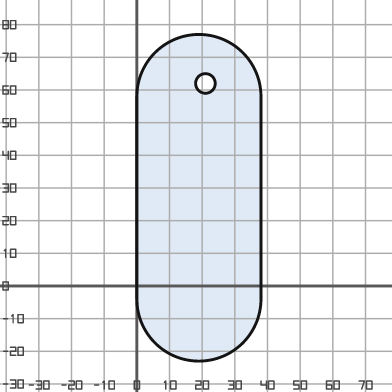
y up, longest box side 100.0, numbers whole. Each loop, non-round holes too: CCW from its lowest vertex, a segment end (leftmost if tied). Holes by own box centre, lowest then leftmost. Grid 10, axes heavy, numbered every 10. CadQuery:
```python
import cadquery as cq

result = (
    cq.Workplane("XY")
    .moveTo(0.0, -4.0)
    .threePointArc((19.0, -23.0), (38.0, -4.0))
    .lineTo(38.0, 58.0)
    .threePointArc((19.0, 77.0), (0.0, 58.0))
    .close()
    .moveTo(21.0, 62.0)
    .circle(3.0)
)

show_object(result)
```